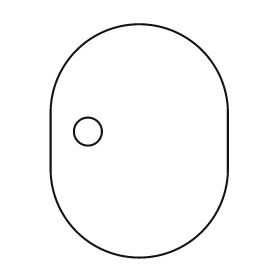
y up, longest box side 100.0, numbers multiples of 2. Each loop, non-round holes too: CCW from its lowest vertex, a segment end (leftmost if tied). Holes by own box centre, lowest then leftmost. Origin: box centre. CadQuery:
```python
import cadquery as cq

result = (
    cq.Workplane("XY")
    .moveTo(-38.0, -12.0)
    .threePointArc((0.0, -50.0), (38.0, -12.0))
    .lineTo(38.0, 12.0)
    .threePointArc((0.0, 50.0), (-38.0, 12.0))
    .close()
    .moveTo(-22.0, 4.0)
    .circle(6.0)
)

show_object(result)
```